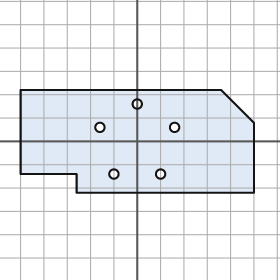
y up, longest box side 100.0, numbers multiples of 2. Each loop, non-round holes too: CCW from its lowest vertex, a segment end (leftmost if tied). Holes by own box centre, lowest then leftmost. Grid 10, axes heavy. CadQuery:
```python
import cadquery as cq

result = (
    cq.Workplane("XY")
    .moveTo(-26.0, -22.0)
    .lineTo(50.0, -22.0)
    .lineTo(50.0, 8.0)
    .lineTo(36.0, 22.0)
    .lineTo(-50.0, 22.0)
    .lineTo(-50.0, -14.0)
    .lineTo(-26.0, -14.0)
    .close()
    .moveTo(-10.0, -14.0)
    .circle(2.0)
    .moveTo(10.0, -14.0)
    .circle(2.0)
    .moveTo(-16.0, 6.0)
    .circle(2.0)
    .moveTo(16.0, 6.0)
    .circle(2.0)
    .moveTo(0.0, 16.0)
    .circle(2.0)
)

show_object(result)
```